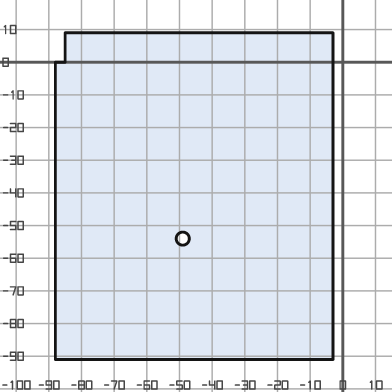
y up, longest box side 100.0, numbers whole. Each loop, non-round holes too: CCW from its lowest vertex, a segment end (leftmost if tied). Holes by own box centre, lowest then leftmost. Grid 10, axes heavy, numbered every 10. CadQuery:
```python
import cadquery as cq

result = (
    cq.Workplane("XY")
    .moveTo(-88.0, -91.0)
    .lineTo(-3.0, -91.0)
    .lineTo(-3.0, 9.0)
    .lineTo(-85.0, 9.0)
    .lineTo(-85.0, 0.0)
    .lineTo(-88.0, 0.0)
    .close()
    .moveTo(-49.0, -54.0)
    .circle(2.0)
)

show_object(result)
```